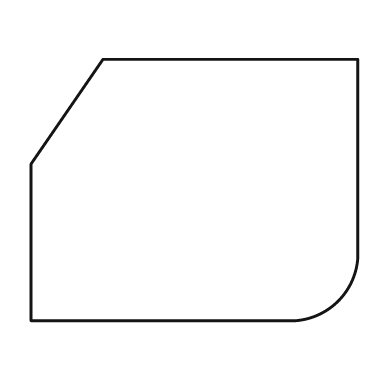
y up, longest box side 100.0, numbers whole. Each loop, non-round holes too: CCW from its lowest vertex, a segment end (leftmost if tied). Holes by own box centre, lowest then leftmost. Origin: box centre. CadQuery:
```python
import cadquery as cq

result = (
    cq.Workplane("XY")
    .moveTo(-50.0, -40.0)
    .lineTo(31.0, -40.0)
    .threePointArc((44.0, -34.0), (50.0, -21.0))
    .lineTo(50.0, 40.0)
    .lineTo(-28.0, 40.0)
    .lineTo(-50.0, 8.0)
    .close()
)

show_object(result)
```